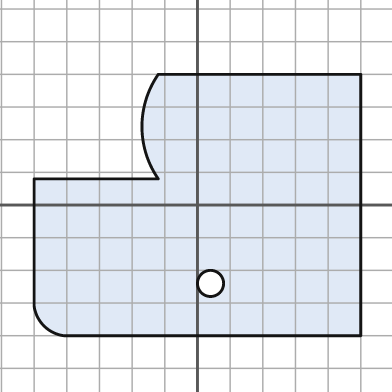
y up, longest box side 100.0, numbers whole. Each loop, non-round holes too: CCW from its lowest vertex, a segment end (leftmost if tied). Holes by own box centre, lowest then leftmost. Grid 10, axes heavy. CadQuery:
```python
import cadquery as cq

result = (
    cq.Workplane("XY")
    .moveTo(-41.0, -40.0)
    .lineTo(50.0, -40.0)
    .lineTo(50.0, 40.0)
    .lineTo(-12.0, 40.0)
    .threePointArc((-17.0, 24.0), (-12.0, 8.0))
    .lineTo(-50.0, 8.0)
    .lineTo(-50.0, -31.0)
    .threePointArc((-47.0, -37.0), (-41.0, -40.0))
    .close()
    .moveTo(4.0, -24.0)
    .circle(4.0)
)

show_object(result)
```